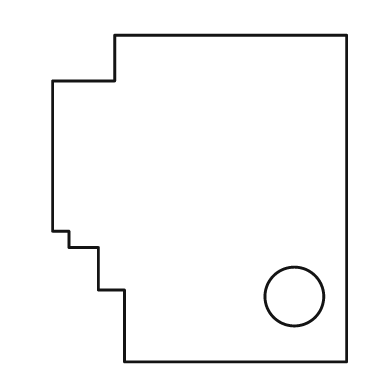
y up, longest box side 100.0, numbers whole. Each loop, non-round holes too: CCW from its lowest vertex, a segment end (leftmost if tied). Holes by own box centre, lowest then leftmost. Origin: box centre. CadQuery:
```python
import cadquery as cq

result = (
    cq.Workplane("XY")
    .moveTo(-23.0, -50.0)
    .lineTo(45.0, -50.0)
    .lineTo(45.0, 50.0)
    .lineTo(-26.0, 50.0)
    .lineTo(-26.0, 36.0)
    .lineTo(-45.0, 36.0)
    .lineTo(-45.0, -10.0)
    .lineTo(-40.0, -10.0)
    .lineTo(-40.0, -15.0)
    .lineTo(-31.0, -15.0)
    .lineTo(-31.0, -28.0)
    .lineTo(-23.0, -28.0)
    .close()
    .moveTo(29.0, -30.0)
    .circle(9.0)
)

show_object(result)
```